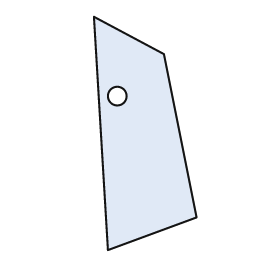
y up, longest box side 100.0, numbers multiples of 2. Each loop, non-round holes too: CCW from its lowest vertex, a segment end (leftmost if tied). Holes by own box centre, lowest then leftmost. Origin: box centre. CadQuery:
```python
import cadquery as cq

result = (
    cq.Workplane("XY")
    .moveTo(-16.0, -50.0)
    .lineTo(22.0, -36.0)
    .lineTo(8.0, 34.0)
    .lineTo(-22.0, 50.0)
    .close()
    .moveTo(-12.0, 16.0)
    .circle(4.0)
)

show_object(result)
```